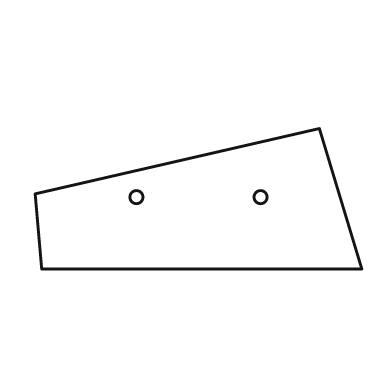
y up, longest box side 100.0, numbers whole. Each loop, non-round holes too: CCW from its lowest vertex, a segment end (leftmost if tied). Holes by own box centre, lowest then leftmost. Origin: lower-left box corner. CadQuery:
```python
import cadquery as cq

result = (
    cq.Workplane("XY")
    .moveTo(2.0, 0.0)
    .lineTo(100.0, 0.0)
    .lineTo(87.0, 43.0)
    .lineTo(0.0, 23.0)
    .close()
    .moveTo(31.0, 22.0)
    .circle(2.0)
    .moveTo(69.0, 22.0)
    .circle(2.0)
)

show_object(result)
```